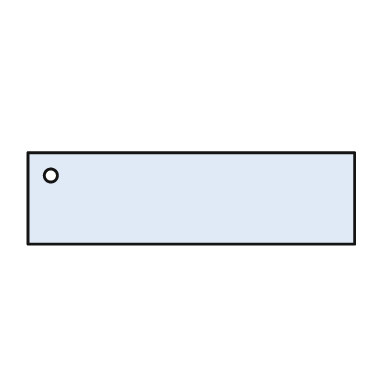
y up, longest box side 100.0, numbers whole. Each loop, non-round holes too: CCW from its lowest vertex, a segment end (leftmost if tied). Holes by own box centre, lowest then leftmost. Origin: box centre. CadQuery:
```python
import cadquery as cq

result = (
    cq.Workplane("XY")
    .moveTo(-50.0, -14.0)
    .lineTo(50.0, -14.0)
    .lineTo(50.0, 14.0)
    .lineTo(-50.0, 14.0)
    .close()
    .moveTo(-43.0, 7.0)
    .circle(2.0)
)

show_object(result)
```